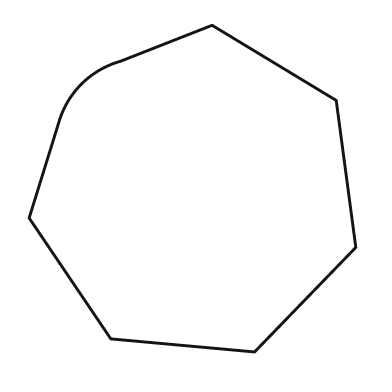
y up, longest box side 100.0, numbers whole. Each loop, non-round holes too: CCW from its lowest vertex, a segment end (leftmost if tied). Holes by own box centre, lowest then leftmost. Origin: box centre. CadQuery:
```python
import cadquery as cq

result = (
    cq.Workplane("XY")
    .moveTo(19.0, -50.0)
    .lineTo(50.0, -18.0)
    .lineTo(44.0, 27.0)
    .lineTo(6.0, 50.0)
    .lineTo(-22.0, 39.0)
    .threePointArc((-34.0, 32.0), (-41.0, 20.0))
    .lineTo(-50.0, -9.0)
    .lineTo(-25.0, -46.0)
    .close()
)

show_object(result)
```